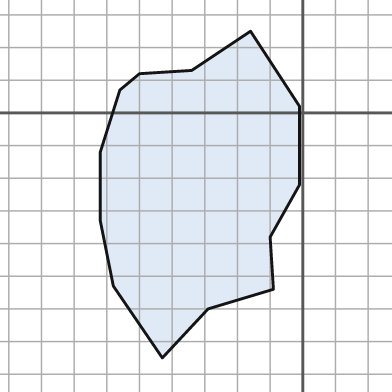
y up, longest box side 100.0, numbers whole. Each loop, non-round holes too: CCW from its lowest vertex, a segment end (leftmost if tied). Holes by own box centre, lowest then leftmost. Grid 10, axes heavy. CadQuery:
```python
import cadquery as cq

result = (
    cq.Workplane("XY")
    .moveTo(-43.0, -75.0)
    .lineTo(-29.0, -60.0)
    .lineTo(-9.0, -54.0)
    .lineTo(-10.0, -38.0)
    .lineTo(-1.0, -22.0)
    .lineTo(-1.0, 2.0)
    .lineTo(-16.0, 25.0)
    .lineTo(-34.0, 13.0)
    .lineTo(-50.0, 12.0)
    .lineTo(-56.0, 7.0)
    .lineTo(-62.0, -12.0)
    .lineTo(-62.0, -33.0)
    .lineTo(-58.0, -53.0)
    .close()
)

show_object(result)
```